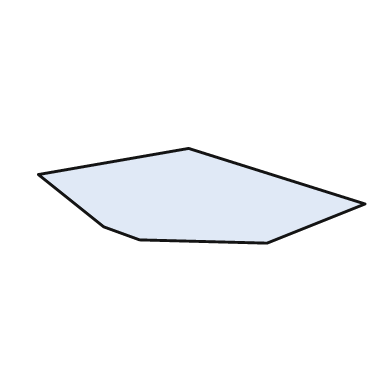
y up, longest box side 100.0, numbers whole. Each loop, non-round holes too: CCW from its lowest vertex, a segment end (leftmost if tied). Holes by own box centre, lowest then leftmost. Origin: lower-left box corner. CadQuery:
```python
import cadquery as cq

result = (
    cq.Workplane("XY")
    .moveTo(70.0, 0.0)
    .lineTo(100.0, 12.0)
    .lineTo(46.0, 29.0)
    .lineTo(0.0, 21.0)
    .lineTo(20.0, 5.0)
    .lineTo(31.0, 1.0)
    .close()
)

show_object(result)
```